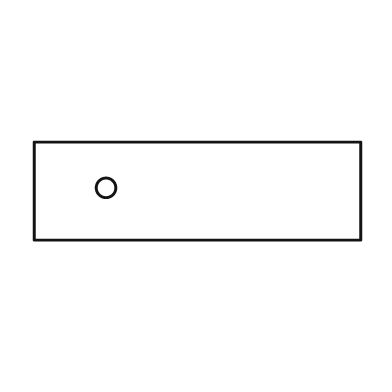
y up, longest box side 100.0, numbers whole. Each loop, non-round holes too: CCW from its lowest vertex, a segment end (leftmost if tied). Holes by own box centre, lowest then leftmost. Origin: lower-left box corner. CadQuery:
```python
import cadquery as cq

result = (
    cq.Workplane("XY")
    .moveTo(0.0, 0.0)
    .lineTo(100.0, 0.0)
    .lineTo(100.0, 30.0)
    .lineTo(0.0, 30.0)
    .close()
    .moveTo(22.0, 16.0)
    .circle(3.0)
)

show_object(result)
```